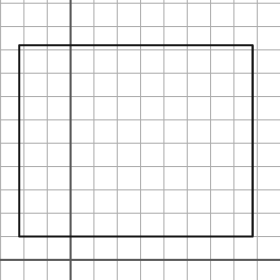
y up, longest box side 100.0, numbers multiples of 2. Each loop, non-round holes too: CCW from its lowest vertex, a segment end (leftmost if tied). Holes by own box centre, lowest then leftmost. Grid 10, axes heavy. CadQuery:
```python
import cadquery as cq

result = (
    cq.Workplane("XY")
    .moveTo(-22.0, 10.0)
    .lineTo(78.0, 10.0)
    .lineTo(78.0, 92.0)
    .lineTo(-22.0, 92.0)
    .close()
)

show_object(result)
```